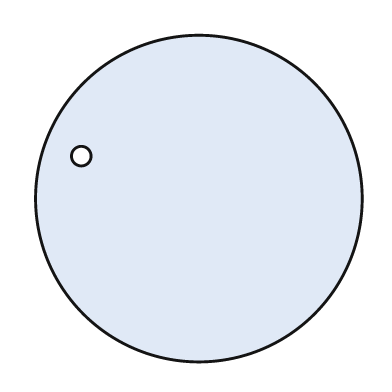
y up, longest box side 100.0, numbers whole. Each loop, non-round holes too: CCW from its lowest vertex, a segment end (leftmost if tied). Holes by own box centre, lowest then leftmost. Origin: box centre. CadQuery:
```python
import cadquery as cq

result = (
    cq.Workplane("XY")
    .moveTo(0.0, 0.0)
    .circle(50.0)
    .moveTo(-36.0, 13.0)
    .circle(3.0)
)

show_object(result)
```